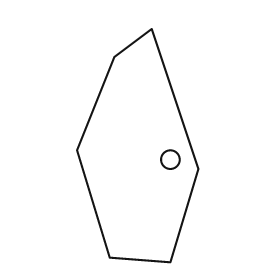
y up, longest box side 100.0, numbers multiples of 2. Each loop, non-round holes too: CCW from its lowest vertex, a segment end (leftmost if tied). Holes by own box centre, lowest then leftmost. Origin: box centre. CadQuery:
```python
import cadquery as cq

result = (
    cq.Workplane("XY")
    .moveTo(14.0, -50.0)
    .lineTo(26.0, -10.0)
    .lineTo(6.0, 50.0)
    .lineTo(-10.0, 38.0)
    .lineTo(-26.0, -2.0)
    .lineTo(-12.0, -48.0)
    .close()
    .moveTo(14.0, -6.0)
    .circle(4.0)
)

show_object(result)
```